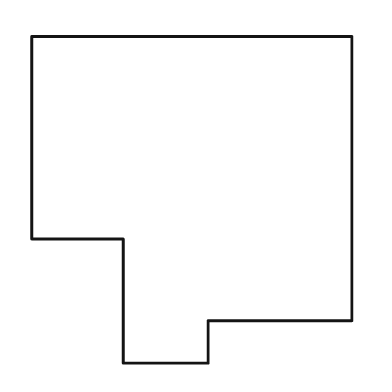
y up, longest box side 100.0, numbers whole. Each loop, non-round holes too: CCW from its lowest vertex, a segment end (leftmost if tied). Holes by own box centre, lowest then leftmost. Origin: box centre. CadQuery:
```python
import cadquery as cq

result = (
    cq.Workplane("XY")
    .moveTo(-21.0, -50.0)
    .lineTo(5.0, -50.0)
    .lineTo(5.0, -37.0)
    .lineTo(49.0, -37.0)
    .lineTo(49.0, 50.0)
    .lineTo(-49.0, 50.0)
    .lineTo(-49.0, -12.0)
    .lineTo(-21.0, -12.0)
    .close()
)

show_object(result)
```